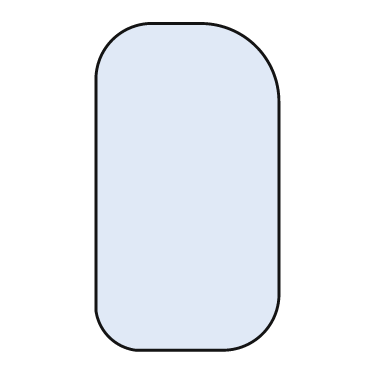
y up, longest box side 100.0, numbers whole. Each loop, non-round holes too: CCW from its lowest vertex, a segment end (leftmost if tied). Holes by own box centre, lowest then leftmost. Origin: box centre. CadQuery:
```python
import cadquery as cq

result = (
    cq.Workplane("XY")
    .moveTo(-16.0, -50.0)
    .lineTo(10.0, -50.0)
    .threePointArc((23.0, -45.0), (28.0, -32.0))
    .lineTo(28.0, 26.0)
    .threePointArc((21.0, 43.0), (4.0, 50.0))
    .lineTo(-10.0, 50.0)
    .threePointArc((-23.0, 45.0), (-28.0, 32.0))
    .lineTo(-28.0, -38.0)
    .threePointArc((-24.0, -46.0), (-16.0, -50.0))
    .close()
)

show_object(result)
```